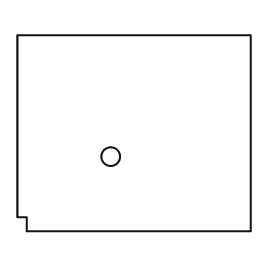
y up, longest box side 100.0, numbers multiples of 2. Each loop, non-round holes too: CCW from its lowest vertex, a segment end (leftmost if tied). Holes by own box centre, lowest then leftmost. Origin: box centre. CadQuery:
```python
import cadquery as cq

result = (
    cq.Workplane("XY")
    .moveTo(-46.0, -42.0)
    .lineTo(50.0, -42.0)
    .lineTo(50.0, 42.0)
    .lineTo(-50.0, 42.0)
    .lineTo(-50.0, -36.0)
    .lineTo(-46.0, -36.0)
    .close()
    .moveTo(-10.0, -10.0)
    .circle(4.0)
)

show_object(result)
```